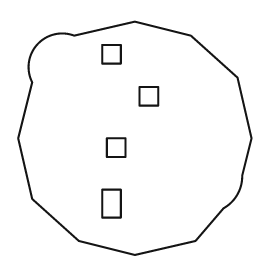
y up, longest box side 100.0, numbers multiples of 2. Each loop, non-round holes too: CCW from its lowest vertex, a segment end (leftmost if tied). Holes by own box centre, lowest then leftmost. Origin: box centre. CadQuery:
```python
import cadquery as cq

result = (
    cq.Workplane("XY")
    .moveTo(0.0, -50.0)
    .lineTo(26.0, -44.0)
    .lineTo(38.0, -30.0)
    .threePointArc((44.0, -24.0), (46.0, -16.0))
    .lineTo(50.0, 0.0)
    .lineTo(44.0, 26.0)
    .lineTo(24.0, 44.0)
    .lineTo(0.0, 50.0)
    .lineTo(-26.0, 44.0)
    .threePointArc((-42.0, 40.0), (-44.0, 24.0))
    .lineTo(-50.0, 0.0)
    .lineTo(-44.0, -26.0)
    .lineTo(-24.0, -44.0)
    .close()
    .moveTo(-14.0, -34.0)
    .lineTo(-6.0, -34.0)
    .lineTo(-6.0, -22.0)
    .lineTo(-14.0, -22.0)
    .close()
    .moveTo(-12.0, -8.0)
    .lineTo(-4.0, -8.0)
    .lineTo(-4.0, 0.0)
    .lineTo(-12.0, 0.0)
    .close()
    .moveTo(2.0, 14.0)
    .lineTo(10.0, 14.0)
    .lineTo(10.0, 22.0)
    .lineTo(2.0, 22.0)
    .close()
    .moveTo(-14.0, 32.0)
    .lineTo(-6.0, 32.0)
    .lineTo(-6.0, 40.0)
    .lineTo(-14.0, 40.0)
    .close()
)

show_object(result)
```